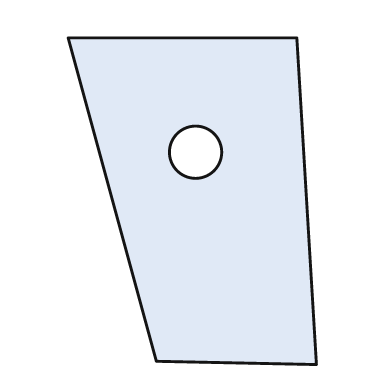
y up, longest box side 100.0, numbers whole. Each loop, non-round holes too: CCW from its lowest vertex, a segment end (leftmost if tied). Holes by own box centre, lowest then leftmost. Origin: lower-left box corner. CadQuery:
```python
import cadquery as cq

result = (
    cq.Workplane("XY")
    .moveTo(76.0, 0.0)
    .lineTo(70.0, 100.0)
    .lineTo(0.0, 100.0)
    .lineTo(27.0, 1.0)
    .close()
    .moveTo(39.0, 65.0)
    .circle(8.0)
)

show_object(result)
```